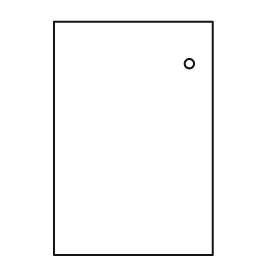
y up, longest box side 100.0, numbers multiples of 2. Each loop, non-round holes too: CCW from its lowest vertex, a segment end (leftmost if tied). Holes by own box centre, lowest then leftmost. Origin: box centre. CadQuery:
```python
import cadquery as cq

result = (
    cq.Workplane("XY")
    .moveTo(-34.0, -50.0)
    .lineTo(34.0, -50.0)
    .lineTo(34.0, 50.0)
    .lineTo(-34.0, 50.0)
    .close()
    .moveTo(24.0, 32.0)
    .circle(2.0)
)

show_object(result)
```